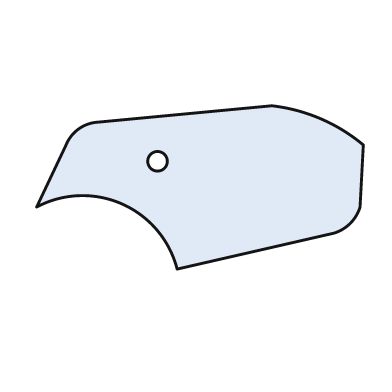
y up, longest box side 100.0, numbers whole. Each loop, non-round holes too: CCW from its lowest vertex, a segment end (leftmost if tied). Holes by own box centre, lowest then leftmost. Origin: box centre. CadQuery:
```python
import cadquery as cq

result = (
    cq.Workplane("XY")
    .moveTo(-7.0, -25.0)
    .lineTo(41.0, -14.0)
    .threePointArc((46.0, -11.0), (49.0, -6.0))
    .lineTo(50.0, 13.0)
    .threePointArc((37.0, 21.0), (22.0, 25.0))
    .lineTo(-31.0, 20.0)
    .threePointArc((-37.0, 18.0), (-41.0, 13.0))
    .lineTo(-50.0, -6.0)
    .threePointArc((-24.0, -5.0), (-7.0, -25.0))
    .close()
    .moveTo(-13.0, 8.0)
    .circle(3.0)
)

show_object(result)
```